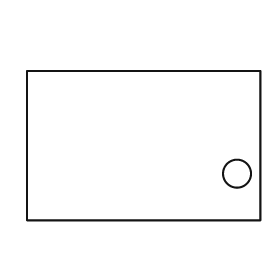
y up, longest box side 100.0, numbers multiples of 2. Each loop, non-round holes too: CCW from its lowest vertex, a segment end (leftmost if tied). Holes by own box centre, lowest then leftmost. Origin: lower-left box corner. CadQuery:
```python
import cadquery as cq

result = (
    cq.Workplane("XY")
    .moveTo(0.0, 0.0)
    .lineTo(100.0, 0.0)
    .lineTo(100.0, 64.0)
    .lineTo(0.0, 64.0)
    .close()
    .moveTo(90.0, 20.0)
    .circle(6.0)
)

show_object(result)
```